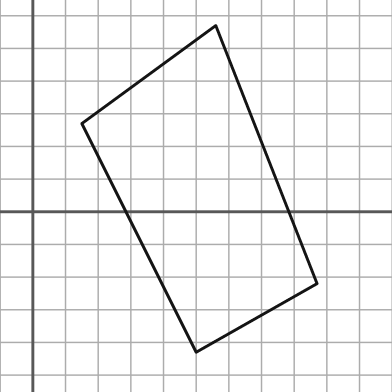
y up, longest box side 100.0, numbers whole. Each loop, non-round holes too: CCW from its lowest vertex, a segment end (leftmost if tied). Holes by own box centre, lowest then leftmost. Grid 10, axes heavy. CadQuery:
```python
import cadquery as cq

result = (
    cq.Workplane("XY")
    .moveTo(50.0, -43.0)
    .lineTo(87.0, -22.0)
    .lineTo(56.0, 57.0)
    .lineTo(15.0, 27.0)
    .close()
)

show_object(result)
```